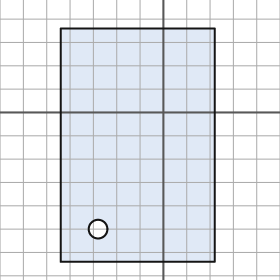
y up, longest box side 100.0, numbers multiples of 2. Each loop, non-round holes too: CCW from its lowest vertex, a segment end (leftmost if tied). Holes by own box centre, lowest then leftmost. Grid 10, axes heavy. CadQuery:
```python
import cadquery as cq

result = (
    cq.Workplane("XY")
    .moveTo(-44.0, -64.0)
    .lineTo(22.0, -64.0)
    .lineTo(22.0, 36.0)
    .lineTo(-44.0, 36.0)
    .close()
    .moveTo(-28.0, -50.0)
    .circle(4.0)
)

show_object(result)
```